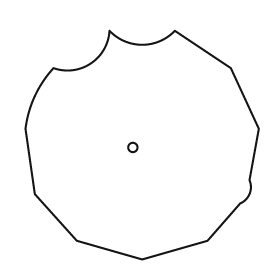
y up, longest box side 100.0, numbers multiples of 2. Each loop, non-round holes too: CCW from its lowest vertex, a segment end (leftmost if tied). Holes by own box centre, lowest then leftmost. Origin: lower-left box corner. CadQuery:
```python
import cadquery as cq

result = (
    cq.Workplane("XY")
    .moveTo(50.0, 0.0)
    .lineTo(78.0, 8.0)
    .lineTo(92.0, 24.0)
    .threePointArc((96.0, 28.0), (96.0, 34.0))
    .lineTo(100.0, 56.0)
    .lineTo(88.0, 82.0)
    .lineTo(64.0, 98.0)
    .threePointArc((50.0, 92.0), (36.0, 98.0))
    .threePointArc((28.0, 84.0), (12.0, 82.0))
    .threePointArc((4.0, 70.0), (0.0, 56.0))
    .lineTo(4.0, 28.0)
    .lineTo(22.0, 8.0)
    .close()
    .moveTo(46.0, 48.0)
    .circle(2.0)
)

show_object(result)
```